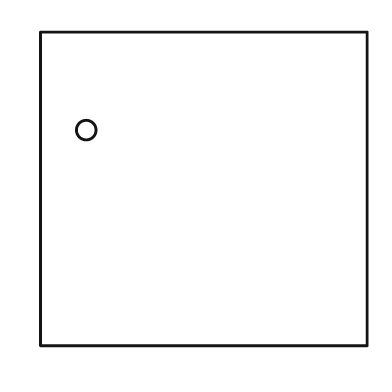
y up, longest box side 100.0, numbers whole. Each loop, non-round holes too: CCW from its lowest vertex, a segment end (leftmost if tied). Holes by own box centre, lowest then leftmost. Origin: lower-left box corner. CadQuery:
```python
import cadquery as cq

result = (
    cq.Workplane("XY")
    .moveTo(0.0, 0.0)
    .lineTo(100.0, 0.0)
    .lineTo(100.0, 96.0)
    .lineTo(0.0, 96.0)
    .close()
    .moveTo(14.0, 66.0)
    .circle(3.0)
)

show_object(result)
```